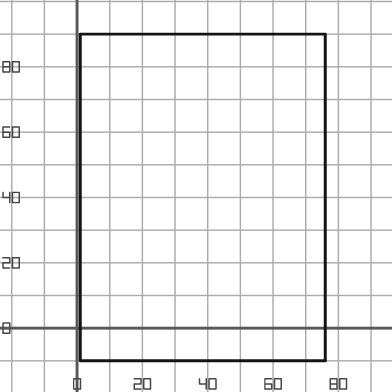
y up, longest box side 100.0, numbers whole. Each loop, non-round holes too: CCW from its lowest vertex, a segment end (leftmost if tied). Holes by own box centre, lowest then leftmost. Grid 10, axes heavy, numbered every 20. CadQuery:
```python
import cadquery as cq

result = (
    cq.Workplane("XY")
    .moveTo(1.0, -10.0)
    .lineTo(76.0, -10.0)
    .lineTo(76.0, 90.0)
    .lineTo(1.0, 90.0)
    .close()
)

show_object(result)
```